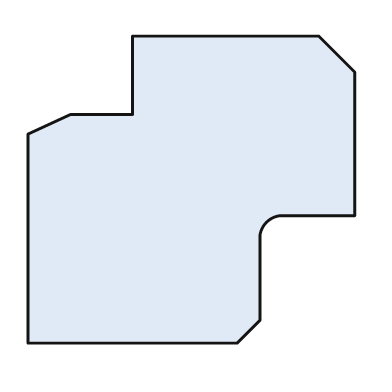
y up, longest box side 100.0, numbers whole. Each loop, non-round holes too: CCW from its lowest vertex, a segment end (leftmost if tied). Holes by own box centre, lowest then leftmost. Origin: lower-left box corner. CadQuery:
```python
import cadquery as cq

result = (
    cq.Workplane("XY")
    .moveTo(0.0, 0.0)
    .lineTo(64.0, 0.0)
    .lineTo(71.0, 7.0)
    .lineTo(71.0, 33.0)
    .threePointArc((73.0, 37.0), (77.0, 39.0))
    .lineTo(100.0, 39.0)
    .lineTo(100.0, 83.0)
    .lineTo(89.0, 94.0)
    .lineTo(32.0, 94.0)
    .lineTo(32.0, 70.0)
    .lineTo(13.0, 70.0)
    .lineTo(0.0, 64.0)
    .close()
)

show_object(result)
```